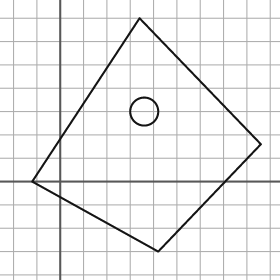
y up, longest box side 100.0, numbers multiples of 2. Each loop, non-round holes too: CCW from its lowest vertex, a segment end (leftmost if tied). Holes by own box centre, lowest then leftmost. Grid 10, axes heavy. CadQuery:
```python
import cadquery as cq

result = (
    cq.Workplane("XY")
    .moveTo(42.0, -30.0)
    .lineTo(86.0, 16.0)
    .lineTo(34.0, 70.0)
    .lineTo(-12.0, 0.0)
    .close()
    .moveTo(36.0, 30.0)
    .circle(6.0)
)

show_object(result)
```